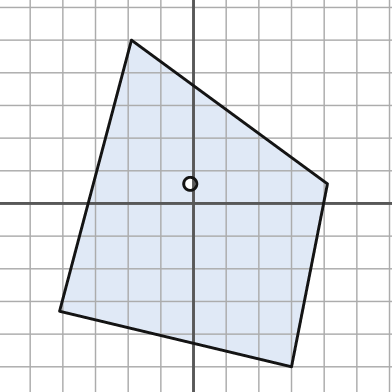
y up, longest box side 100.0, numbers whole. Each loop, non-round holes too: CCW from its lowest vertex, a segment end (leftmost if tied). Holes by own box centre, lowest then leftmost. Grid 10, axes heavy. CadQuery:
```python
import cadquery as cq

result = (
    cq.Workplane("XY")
    .moveTo(30.0, -50.0)
    .lineTo(41.0, 6.0)
    .lineTo(-19.0, 50.0)
    .lineTo(-41.0, -33.0)
    .close()
    .moveTo(-1.0, 6.0)
    .circle(2.0)
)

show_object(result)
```